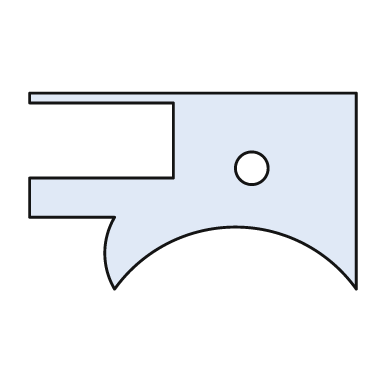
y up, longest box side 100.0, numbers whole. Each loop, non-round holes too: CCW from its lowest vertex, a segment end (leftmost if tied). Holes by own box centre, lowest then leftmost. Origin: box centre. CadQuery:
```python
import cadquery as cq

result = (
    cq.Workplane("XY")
    .moveTo(-24.0, -30.0)
    .threePointArc((13.0, -11.0), (50.0, -30.0))
    .lineTo(50.0, 30.0)
    .lineTo(-50.0, 30.0)
    .lineTo(-50.0, 27.0)
    .lineTo(-6.0, 27.0)
    .lineTo(-6.0, 4.0)
    .lineTo(-50.0, 4.0)
    .lineTo(-50.0, -8.0)
    .lineTo(-24.0, -8.0)
    .threePointArc((-27.0, -19.0), (-24.0, -30.0))
    .close()
    .moveTo(18.0, 7.0)
    .circle(5.0)
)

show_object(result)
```